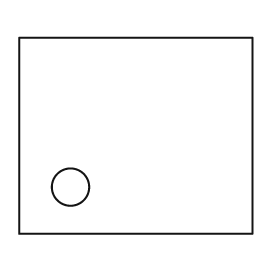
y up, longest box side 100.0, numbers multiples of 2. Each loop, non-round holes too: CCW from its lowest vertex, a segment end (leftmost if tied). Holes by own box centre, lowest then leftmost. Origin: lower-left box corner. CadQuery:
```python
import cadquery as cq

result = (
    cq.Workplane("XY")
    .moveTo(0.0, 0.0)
    .lineTo(100.0, 0.0)
    .lineTo(100.0, 84.0)
    .lineTo(0.0, 84.0)
    .close()
    .moveTo(22.0, 20.0)
    .circle(8.0)
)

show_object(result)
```